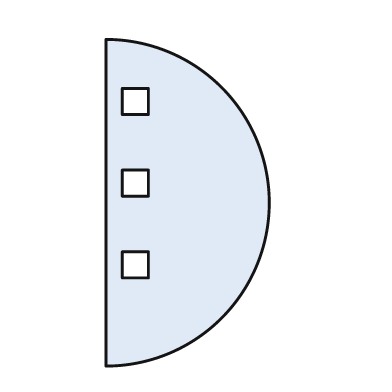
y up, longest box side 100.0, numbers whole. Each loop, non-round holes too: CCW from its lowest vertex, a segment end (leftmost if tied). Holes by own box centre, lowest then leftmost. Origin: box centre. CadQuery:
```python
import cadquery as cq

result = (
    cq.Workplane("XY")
    .moveTo(-25.0, -50.0)
    .threePointArc((25.0, 0.0), (-25.0, 50.0))
    .close()
    .moveTo(-20.0, -23.0)
    .lineTo(-12.0, -23.0)
    .lineTo(-12.0, -15.0)
    .lineTo(-20.0, -15.0)
    .close()
    .moveTo(-20.0, 2.0)
    .lineTo(-12.0, 2.0)
    .lineTo(-12.0, 10.0)
    .lineTo(-20.0, 10.0)
    .close()
    .moveTo(-20.0, 27.0)
    .lineTo(-12.0, 27.0)
    .lineTo(-12.0, 35.0)
    .lineTo(-20.0, 35.0)
    .close()
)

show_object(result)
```